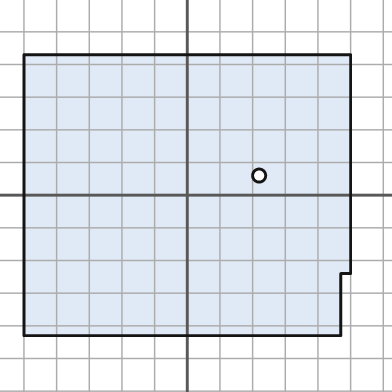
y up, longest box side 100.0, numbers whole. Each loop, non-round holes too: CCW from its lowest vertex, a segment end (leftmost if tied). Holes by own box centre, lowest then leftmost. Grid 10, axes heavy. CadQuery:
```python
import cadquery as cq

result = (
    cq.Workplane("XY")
    .moveTo(-50.0, -43.0)
    .lineTo(47.0, -43.0)
    .lineTo(47.0, -24.0)
    .lineTo(50.0, -24.0)
    .lineTo(50.0, 43.0)
    .lineTo(-50.0, 43.0)
    .close()
    .moveTo(22.0, 6.0)
    .circle(2.0)
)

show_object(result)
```